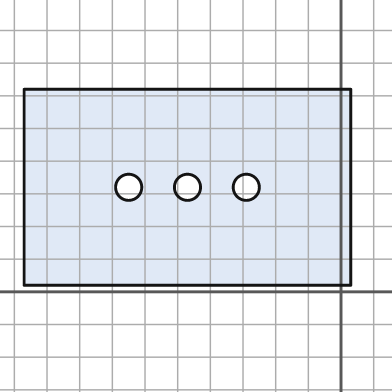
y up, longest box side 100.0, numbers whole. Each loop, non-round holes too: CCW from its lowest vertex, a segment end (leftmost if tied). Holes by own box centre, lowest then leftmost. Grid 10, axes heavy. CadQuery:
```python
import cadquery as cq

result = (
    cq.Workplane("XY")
    .moveTo(-97.0, 2.0)
    .lineTo(3.0, 2.0)
    .lineTo(3.0, 62.0)
    .lineTo(-97.0, 62.0)
    .close()
    .moveTo(-65.0, 32.0)
    .circle(4.0)
    .moveTo(-47.0, 32.0)
    .circle(4.0)
    .moveTo(-29.0, 32.0)
    .circle(4.0)
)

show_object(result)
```